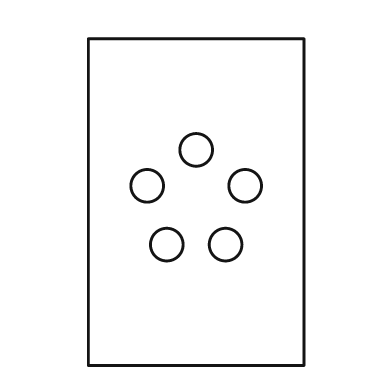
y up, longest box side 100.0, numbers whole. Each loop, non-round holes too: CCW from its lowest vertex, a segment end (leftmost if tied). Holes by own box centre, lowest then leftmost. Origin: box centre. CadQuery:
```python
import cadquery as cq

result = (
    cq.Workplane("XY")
    .moveTo(-33.0, -50.0)
    .lineTo(33.0, -50.0)
    .lineTo(33.0, 50.0)
    .lineTo(-33.0, 50.0)
    .close()
    .moveTo(-9.0, -13.0)
    .circle(5.0)
    .moveTo(9.0, -13.0)
    .circle(5.0)
    .moveTo(-15.0, 5.0)
    .circle(5.0)
    .moveTo(15.0, 5.0)
    .circle(5.0)
    .moveTo(0.0, 16.0)
    .circle(5.0)
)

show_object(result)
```